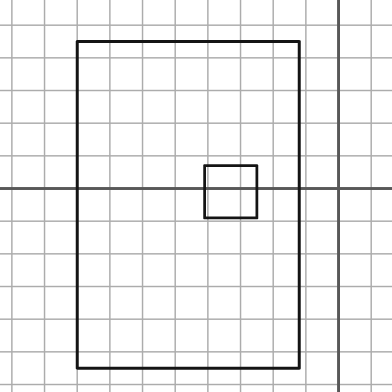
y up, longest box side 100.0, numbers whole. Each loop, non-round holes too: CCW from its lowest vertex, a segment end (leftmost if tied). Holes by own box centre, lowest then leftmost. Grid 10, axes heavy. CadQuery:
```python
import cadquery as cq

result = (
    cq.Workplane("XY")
    .moveTo(-80.0, -55.0)
    .lineTo(-12.0, -55.0)
    .lineTo(-12.0, 45.0)
    .lineTo(-80.0, 45.0)
    .close()
    .moveTo(-41.0, -9.0)
    .lineTo(-25.0, -9.0)
    .lineTo(-25.0, 7.0)
    .lineTo(-41.0, 7.0)
    .close()
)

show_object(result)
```